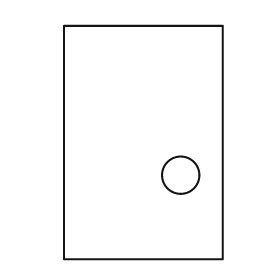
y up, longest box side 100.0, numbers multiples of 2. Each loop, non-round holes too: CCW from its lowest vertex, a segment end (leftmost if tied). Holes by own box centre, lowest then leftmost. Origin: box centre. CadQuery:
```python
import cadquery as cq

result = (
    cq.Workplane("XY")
    .moveTo(-34.0, -50.0)
    .lineTo(34.0, -50.0)
    .lineTo(34.0, 50.0)
    .lineTo(-34.0, 50.0)
    .close()
    .moveTo(16.0, -14.0)
    .circle(8.0)
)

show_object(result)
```